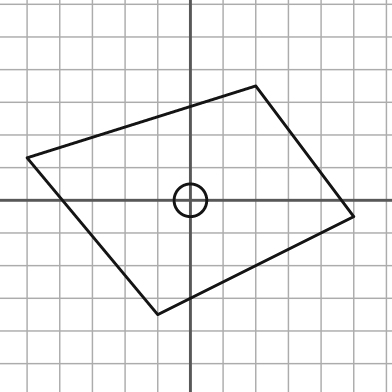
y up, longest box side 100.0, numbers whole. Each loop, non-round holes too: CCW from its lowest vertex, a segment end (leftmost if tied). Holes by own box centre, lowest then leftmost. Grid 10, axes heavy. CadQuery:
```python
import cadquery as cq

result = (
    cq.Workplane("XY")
    .moveTo(-10.0, -35.0)
    .lineTo(50.0, -5.0)
    .lineTo(20.0, 35.0)
    .lineTo(-50.0, 13.0)
    .close()
    .moveTo(0.0, 0.0)
    .circle(5.0)
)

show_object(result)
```